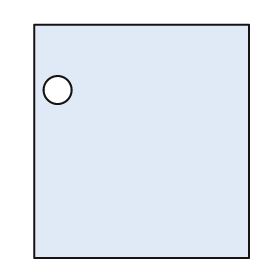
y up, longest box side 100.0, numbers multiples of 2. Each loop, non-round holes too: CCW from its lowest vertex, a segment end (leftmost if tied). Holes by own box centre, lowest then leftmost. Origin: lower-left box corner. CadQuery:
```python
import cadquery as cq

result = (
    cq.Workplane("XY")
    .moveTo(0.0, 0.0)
    .lineTo(92.0, 0.0)
    .lineTo(92.0, 100.0)
    .lineTo(0.0, 100.0)
    .close()
    .moveTo(10.0, 72.0)
    .circle(6.0)
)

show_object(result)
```